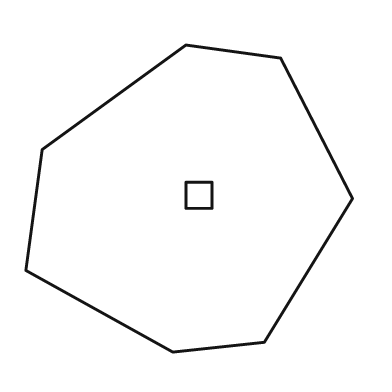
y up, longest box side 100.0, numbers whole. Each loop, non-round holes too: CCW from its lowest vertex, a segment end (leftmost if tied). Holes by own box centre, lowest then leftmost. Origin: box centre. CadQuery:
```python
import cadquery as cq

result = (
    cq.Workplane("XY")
    .moveTo(-5.0, -47.0)
    .lineTo(23.0, -44.0)
    .lineTo(50.0, 0.0)
    .lineTo(28.0, 43.0)
    .lineTo(-1.0, 47.0)
    .lineTo(-45.0, 15.0)
    .lineTo(-50.0, -22.0)
    .close()
    .moveTo(-1.0, -3.0)
    .lineTo(7.0, -3.0)
    .lineTo(7.0, 5.0)
    .lineTo(-1.0, 5.0)
    .close()
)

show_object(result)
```